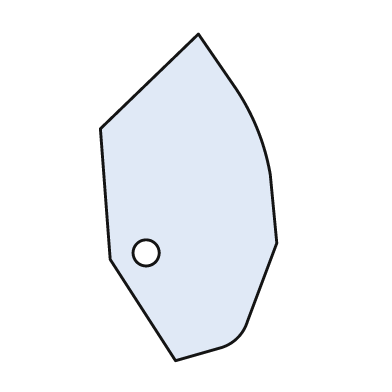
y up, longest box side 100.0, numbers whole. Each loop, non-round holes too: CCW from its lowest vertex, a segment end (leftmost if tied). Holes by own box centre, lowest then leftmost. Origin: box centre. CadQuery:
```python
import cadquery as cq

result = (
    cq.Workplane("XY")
    .moveTo(-4.0, -50.0)
    .lineTo(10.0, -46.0)
    .threePointArc((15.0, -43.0), (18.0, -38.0))
    .lineTo(27.0, -14.0)
    .lineTo(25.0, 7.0)
    .threePointArc((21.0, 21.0), (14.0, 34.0))
    .lineTo(3.0, 50.0)
    .lineTo(-27.0, 21.0)
    .lineTo(-24.0, -19.0)
    .close()
    .moveTo(-13.0, -17.0)
    .circle(4.0)
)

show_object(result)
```